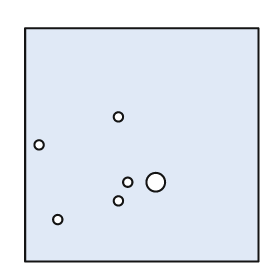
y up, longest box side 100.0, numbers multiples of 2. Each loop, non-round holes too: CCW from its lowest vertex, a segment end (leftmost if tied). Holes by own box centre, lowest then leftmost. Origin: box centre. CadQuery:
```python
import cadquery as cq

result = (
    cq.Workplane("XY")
    .moveTo(-50.0, -50.0)
    .lineTo(50.0, -50.0)
    .lineTo(50.0, 50.0)
    .lineTo(-50.0, 50.0)
    .close()
    .moveTo(-36.0, -32.0)
    .circle(2.0)
    .moveTo(-10.0, -24.0)
    .circle(2.0)
    .moveTo(-6.0, -16.0)
    .circle(2.0)
    .moveTo(6.0, -16.0)
    .circle(4.0)
    .moveTo(-44.0, 0.0)
    .circle(2.0)
    .moveTo(-10.0, 12.0)
    .circle(2.0)
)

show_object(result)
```